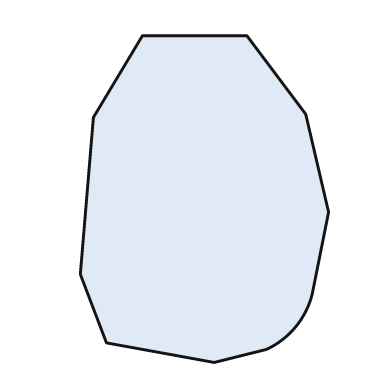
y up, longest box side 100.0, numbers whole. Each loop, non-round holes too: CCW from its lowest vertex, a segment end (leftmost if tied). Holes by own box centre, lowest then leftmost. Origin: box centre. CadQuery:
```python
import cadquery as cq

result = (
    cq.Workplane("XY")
    .moveTo(3.0, -50.0)
    .lineTo(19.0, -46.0)
    .threePointArc((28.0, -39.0), (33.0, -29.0))
    .lineTo(38.0, -4.0)
    .lineTo(31.0, 26.0)
    .lineTo(13.0, 50.0)
    .lineTo(-19.0, 50.0)
    .lineTo(-34.0, 25.0)
    .lineTo(-38.0, -23.0)
    .lineTo(-30.0, -44.0)
    .close()
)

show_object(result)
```